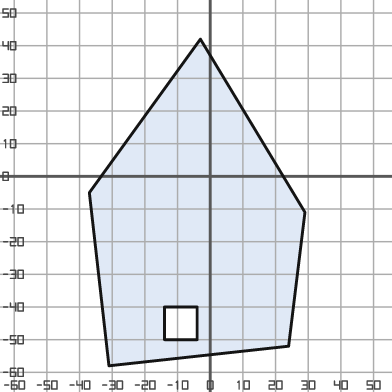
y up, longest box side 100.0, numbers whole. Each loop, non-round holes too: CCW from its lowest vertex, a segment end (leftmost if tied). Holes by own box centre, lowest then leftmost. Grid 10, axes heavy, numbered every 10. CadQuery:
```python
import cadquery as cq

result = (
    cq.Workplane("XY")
    .moveTo(-31.0, -58.0)
    .lineTo(24.0, -52.0)
    .lineTo(29.0, -11.0)
    .lineTo(-3.0, 42.0)
    .lineTo(-37.0, -5.0)
    .close()
    .moveTo(-14.0, -50.0)
    .lineTo(-4.0, -50.0)
    .lineTo(-4.0, -40.0)
    .lineTo(-14.0, -40.0)
    .close()
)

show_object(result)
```